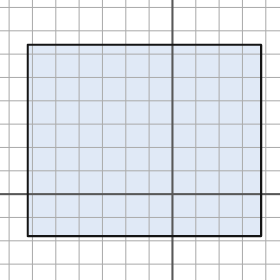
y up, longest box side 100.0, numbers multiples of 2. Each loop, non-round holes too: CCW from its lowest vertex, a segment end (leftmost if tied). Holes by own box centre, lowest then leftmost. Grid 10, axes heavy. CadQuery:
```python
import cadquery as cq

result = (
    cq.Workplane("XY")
    .moveTo(-62.0, -18.0)
    .lineTo(38.0, -18.0)
    .lineTo(38.0, 64.0)
    .lineTo(-62.0, 64.0)
    .close()
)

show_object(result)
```